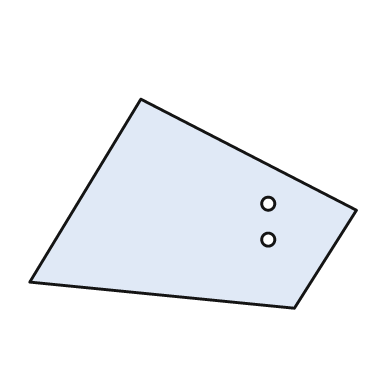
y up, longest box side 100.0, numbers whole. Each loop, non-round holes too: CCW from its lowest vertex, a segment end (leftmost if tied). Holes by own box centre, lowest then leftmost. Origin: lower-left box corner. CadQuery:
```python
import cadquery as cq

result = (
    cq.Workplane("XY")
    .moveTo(81.0, 0.0)
    .lineTo(100.0, 30.0)
    .lineTo(34.0, 64.0)
    .lineTo(0.0, 8.0)
    .close()
    .moveTo(73.0, 21.0)
    .circle(2.0)
    .moveTo(73.0, 32.0)
    .circle(2.0)
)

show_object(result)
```